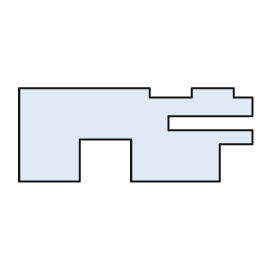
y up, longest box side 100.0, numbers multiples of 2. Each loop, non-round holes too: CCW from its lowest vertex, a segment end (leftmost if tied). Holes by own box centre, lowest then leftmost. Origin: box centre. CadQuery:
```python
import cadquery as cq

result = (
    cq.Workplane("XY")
    .moveTo(-50.0, -20.0)
    .lineTo(-24.0, -20.0)
    .lineTo(-24.0, -2.0)
    .lineTo(-2.0, -2.0)
    .lineTo(-2.0, -20.0)
    .lineTo(36.0, -20.0)
    .lineTo(36.0, -4.0)
    .lineTo(50.0, -4.0)
    .lineTo(50.0, 2.0)
    .lineTo(14.0, 2.0)
    .lineTo(14.0, 8.0)
    .lineTo(50.0, 8.0)
    .lineTo(50.0, 16.0)
    .lineTo(42.0, 16.0)
    .lineTo(42.0, 20.0)
    .lineTo(24.0, 20.0)
    .lineTo(24.0, 16.0)
    .lineTo(6.0, 16.0)
    .lineTo(6.0, 20.0)
    .lineTo(-50.0, 20.0)
    .close()
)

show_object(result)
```